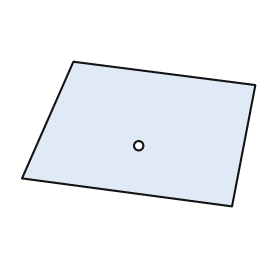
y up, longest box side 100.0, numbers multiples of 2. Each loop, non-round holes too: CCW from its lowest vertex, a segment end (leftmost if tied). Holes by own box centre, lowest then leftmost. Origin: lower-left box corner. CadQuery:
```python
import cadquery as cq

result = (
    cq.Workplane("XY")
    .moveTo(90.0, 0.0)
    .lineTo(100.0, 52.0)
    .lineTo(22.0, 62.0)
    .lineTo(0.0, 12.0)
    .close()
    .moveTo(50.0, 26.0)
    .circle(2.0)
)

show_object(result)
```